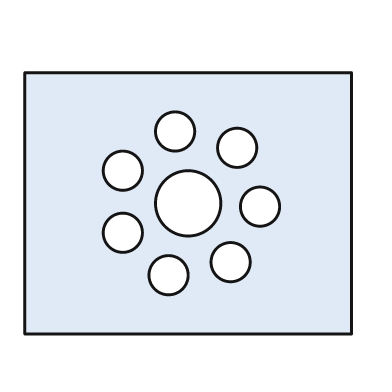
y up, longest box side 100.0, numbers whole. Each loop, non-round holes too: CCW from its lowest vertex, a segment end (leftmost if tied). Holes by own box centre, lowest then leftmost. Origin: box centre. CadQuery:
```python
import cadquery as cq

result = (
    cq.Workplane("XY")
    .moveTo(-50.0, -40.0)
    .lineTo(50.0, -40.0)
    .lineTo(50.0, 40.0)
    .lineTo(-50.0, 40.0)
    .close()
    .moveTo(-6.0, -22.0)
    .circle(6.0)
    .moveTo(13.0, -18.0)
    .circle(6.0)
    .moveTo(-20.0, -9.0)
    .circle(6.0)
    .moveTo(22.0, -1.0)
    .circle(6.0)
    .moveTo(0.0, 0.0)
    .circle(10.0)
    .moveTo(-20.0, 10.0)
    .circle(6.0)
    .moveTo(15.0, 17.0)
    .circle(6.0)
    .moveTo(-4.0, 22.0)
    .circle(6.0)
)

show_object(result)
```